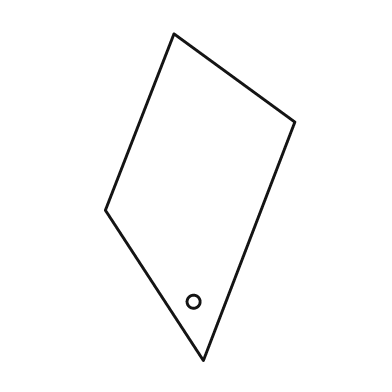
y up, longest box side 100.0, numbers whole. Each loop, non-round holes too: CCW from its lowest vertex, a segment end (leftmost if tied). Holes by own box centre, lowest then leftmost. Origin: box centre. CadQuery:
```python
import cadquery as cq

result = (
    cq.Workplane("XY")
    .moveTo(1.0, -50.0)
    .lineTo(29.0, 23.0)
    .lineTo(-8.0, 50.0)
    .lineTo(-29.0, -4.0)
    .close()
    .moveTo(-2.0, -32.0)
    .circle(2.0)
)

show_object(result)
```